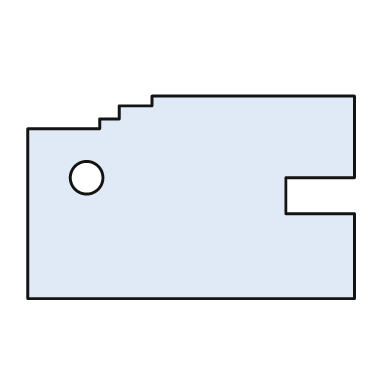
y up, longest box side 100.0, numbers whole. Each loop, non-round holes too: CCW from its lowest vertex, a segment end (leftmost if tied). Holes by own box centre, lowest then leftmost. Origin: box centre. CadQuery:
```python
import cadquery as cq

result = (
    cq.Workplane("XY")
    .moveTo(-50.0, -31.0)
    .lineTo(50.0, -31.0)
    .lineTo(50.0, -5.0)
    .lineTo(29.0, -5.0)
    .lineTo(29.0, 6.0)
    .lineTo(50.0, 6.0)
    .lineTo(50.0, 31.0)
    .lineTo(-12.0, 31.0)
    .lineTo(-12.0, 28.0)
    .lineTo(-22.0, 28.0)
    .lineTo(-22.0, 24.0)
    .lineTo(-28.0, 24.0)
    .lineTo(-28.0, 21.0)
    .lineTo(-50.0, 21.0)
    .close()
    .moveTo(-32.0, 6.0)
    .circle(5.0)
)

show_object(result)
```